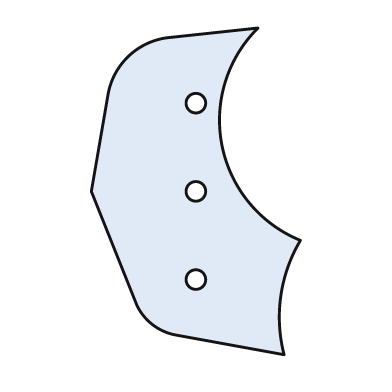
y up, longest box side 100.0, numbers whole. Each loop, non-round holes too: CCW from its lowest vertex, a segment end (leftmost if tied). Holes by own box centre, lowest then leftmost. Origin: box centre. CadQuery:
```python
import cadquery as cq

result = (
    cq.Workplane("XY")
    .moveTo(27.0, -50.0)
    .threePointArc((26.0, -32.0), (32.0, -15.0))
    .threePointArc((8.0, 14.0), (19.0, 50.0))
    .lineTo(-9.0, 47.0)
    .threePointArc((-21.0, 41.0), (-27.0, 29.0))
    .lineTo(-32.0, 0.0)
    .lineTo(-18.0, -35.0)
    .threePointArc((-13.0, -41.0), (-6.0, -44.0))
    .close()
    .moveTo(0.0, -27.0)
    .circle(3.0)
    .moveTo(0.0, 0.0)
    .circle(3.0)
    .moveTo(0.0, 27.0)
    .circle(3.0)
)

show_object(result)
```